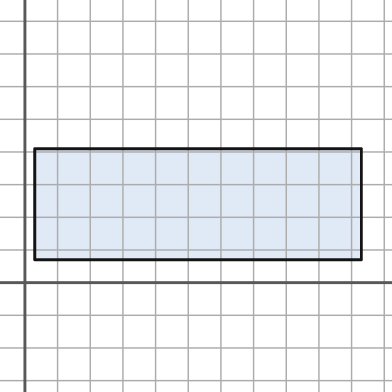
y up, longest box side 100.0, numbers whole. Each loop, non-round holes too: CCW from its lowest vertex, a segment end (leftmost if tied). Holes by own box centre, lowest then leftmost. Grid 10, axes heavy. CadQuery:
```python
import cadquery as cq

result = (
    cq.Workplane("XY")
    .moveTo(3.0, 7.0)
    .lineTo(103.0, 7.0)
    .lineTo(103.0, 41.0)
    .lineTo(3.0, 41.0)
    .close()
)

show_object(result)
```